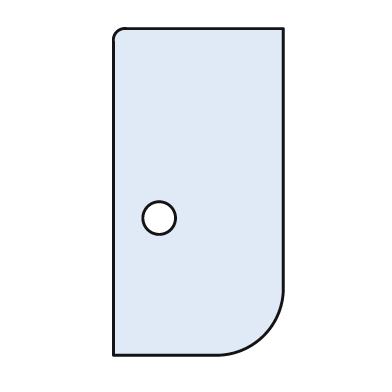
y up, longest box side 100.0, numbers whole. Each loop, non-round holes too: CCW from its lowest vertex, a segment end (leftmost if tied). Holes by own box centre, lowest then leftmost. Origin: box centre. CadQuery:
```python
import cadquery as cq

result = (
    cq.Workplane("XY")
    .moveTo(-26.0, -50.0)
    .lineTo(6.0, -50.0)
    .threePointArc((20.0, -44.0), (26.0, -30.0))
    .lineTo(26.0, 50.0)
    .lineTo(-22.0, 50.0)
    .threePointArc((-25.0, 49.0), (-26.0, 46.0))
    .close()
    .moveTo(-12.0, -8.0)
    .circle(5.0)
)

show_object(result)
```